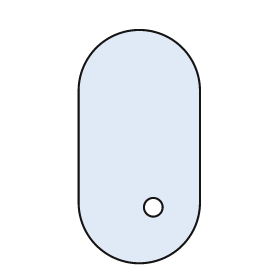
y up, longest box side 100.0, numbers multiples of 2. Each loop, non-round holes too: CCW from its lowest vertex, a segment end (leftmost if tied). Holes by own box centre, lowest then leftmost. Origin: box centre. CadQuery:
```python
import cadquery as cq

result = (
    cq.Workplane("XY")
    .moveTo(-26.0, -24.0)
    .threePointArc((0.0, -50.0), (26.0, -24.0))
    .lineTo(26.0, 24.0)
    .threePointArc((0.0, 50.0), (-26.0, 24.0))
    .close()
    .moveTo(6.0, -26.0)
    .circle(4.0)
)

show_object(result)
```